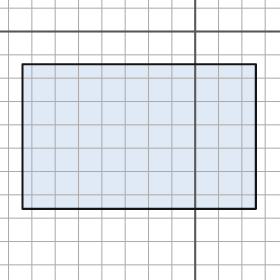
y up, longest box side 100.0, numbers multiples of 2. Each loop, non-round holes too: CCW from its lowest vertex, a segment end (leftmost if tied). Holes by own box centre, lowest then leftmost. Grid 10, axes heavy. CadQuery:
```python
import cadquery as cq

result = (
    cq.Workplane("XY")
    .moveTo(-74.0, -76.0)
    .lineTo(26.0, -76.0)
    .lineTo(26.0, -14.0)
    .lineTo(-74.0, -14.0)
    .close()
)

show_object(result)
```